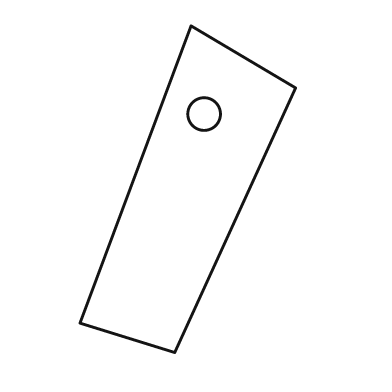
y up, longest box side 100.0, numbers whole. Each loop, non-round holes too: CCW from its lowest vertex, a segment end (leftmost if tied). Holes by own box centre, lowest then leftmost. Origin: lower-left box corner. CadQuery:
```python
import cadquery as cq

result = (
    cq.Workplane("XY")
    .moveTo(29.0, 0.0)
    .lineTo(66.0, 81.0)
    .lineTo(34.0, 100.0)
    .lineTo(0.0, 9.0)
    .close()
    .moveTo(38.0, 73.0)
    .circle(5.0)
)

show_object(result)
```